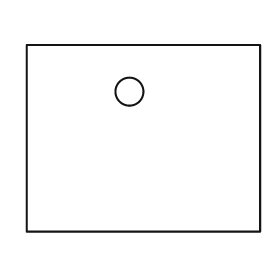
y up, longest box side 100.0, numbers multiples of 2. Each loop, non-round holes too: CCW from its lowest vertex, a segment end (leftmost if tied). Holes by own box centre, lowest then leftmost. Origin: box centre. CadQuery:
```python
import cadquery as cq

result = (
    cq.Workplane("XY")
    .moveTo(-50.0, -40.0)
    .lineTo(50.0, -40.0)
    .lineTo(50.0, 40.0)
    .lineTo(-50.0, 40.0)
    .close()
    .moveTo(-6.0, 20.0)
    .circle(6.0)
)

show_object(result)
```